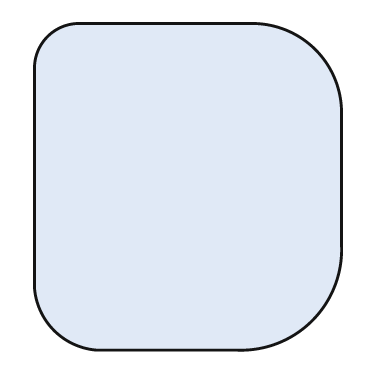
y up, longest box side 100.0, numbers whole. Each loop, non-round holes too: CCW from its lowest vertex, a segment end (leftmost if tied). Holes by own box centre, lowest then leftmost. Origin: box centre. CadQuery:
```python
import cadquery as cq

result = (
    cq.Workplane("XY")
    .moveTo(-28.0, -50.0)
    .lineTo(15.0, -50.0)
    .threePointArc((38.0, -41.0), (47.0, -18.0))
    .lineTo(47.0, 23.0)
    .threePointArc((39.0, 42.0), (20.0, 50.0))
    .lineTo(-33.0, 50.0)
    .threePointArc((-43.0, 46.0), (-47.0, 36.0))
    .lineTo(-47.0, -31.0)
    .threePointArc((-41.0, -44.0), (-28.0, -50.0))
    .close()
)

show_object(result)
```